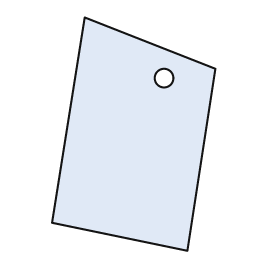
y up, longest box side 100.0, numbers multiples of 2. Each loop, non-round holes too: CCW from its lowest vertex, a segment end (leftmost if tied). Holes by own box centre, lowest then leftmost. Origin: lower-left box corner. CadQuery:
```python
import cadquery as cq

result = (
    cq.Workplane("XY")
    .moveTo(58.0, 0.0)
    .lineTo(70.0, 78.0)
    .lineTo(14.0, 100.0)
    .lineTo(0.0, 12.0)
    .close()
    .moveTo(48.0, 74.0)
    .circle(4.0)
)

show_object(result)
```